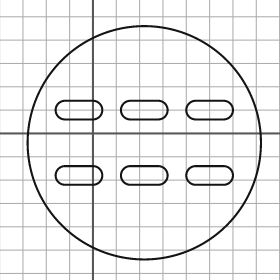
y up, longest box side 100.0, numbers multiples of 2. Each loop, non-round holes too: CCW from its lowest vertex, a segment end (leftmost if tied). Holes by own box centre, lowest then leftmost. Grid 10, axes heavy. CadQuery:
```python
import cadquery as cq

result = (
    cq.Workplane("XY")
    .moveTo(22.0, -4.0)
    .circle(50.0)
    .moveTo(-12.0, -22.0)
    .lineTo(0.0, -22.0)
    .threePointArc((4.0, -18.0), (0.0, -14.0))
    .lineTo(-12.0, -14.0)
    .threePointArc((-16.0, -18.0), (-12.0, -22.0))
    .close()
    .moveTo(16.0, -22.0)
    .lineTo(28.0, -22.0)
    .threePointArc((32.0, -18.0), (28.0, -14.0))
    .lineTo(16.0, -14.0)
    .threePointArc((12.0, -18.0), (16.0, -22.0))
    .close()
    .moveTo(44.0, -22.0)
    .lineTo(56.0, -22.0)
    .threePointArc((60.0, -18.0), (56.0, -14.0))
    .lineTo(44.0, -14.0)
    .threePointArc((40.0, -18.0), (44.0, -22.0))
    .close()
    .moveTo(-12.0, 6.0)
    .lineTo(0.0, 6.0)
    .threePointArc((4.0, 10.0), (0.0, 14.0))
    .lineTo(-12.0, 14.0)
    .threePointArc((-16.0, 10.0), (-12.0, 6.0))
    .close()
    .moveTo(16.0, 6.0)
    .lineTo(28.0, 6.0)
    .threePointArc((32.0, 10.0), (28.0, 14.0))
    .lineTo(16.0, 14.0)
    .threePointArc((12.0, 10.0), (16.0, 6.0))
    .close()
    .moveTo(44.0, 6.0)
    .lineTo(56.0, 6.0)
    .threePointArc((60.0, 10.0), (56.0, 14.0))
    .lineTo(44.0, 14.0)
    .threePointArc((40.0, 10.0), (44.0, 6.0))
    .close()
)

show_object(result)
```